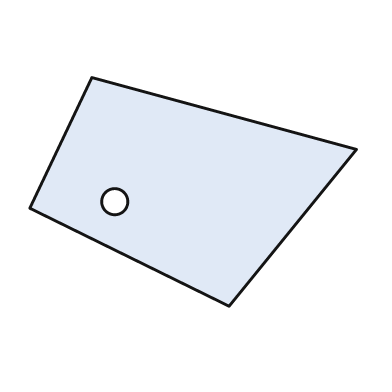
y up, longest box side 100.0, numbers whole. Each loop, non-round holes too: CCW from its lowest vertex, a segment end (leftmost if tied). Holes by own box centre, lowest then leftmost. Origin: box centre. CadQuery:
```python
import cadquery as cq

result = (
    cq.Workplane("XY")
    .moveTo(11.0, -35.0)
    .lineTo(50.0, 13.0)
    .lineTo(-31.0, 35.0)
    .lineTo(-50.0, -5.0)
    .close()
    .moveTo(-24.0, -3.0)
    .circle(4.0)
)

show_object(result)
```